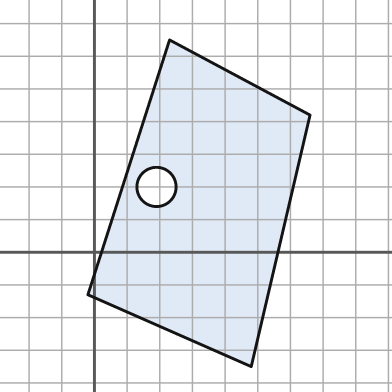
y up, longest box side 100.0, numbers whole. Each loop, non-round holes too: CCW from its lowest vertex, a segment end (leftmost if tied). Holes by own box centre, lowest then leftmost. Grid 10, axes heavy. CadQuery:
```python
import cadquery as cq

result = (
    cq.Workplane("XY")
    .moveTo(48.0, -35.0)
    .lineTo(66.0, 42.0)
    .lineTo(23.0, 65.0)
    .lineTo(-2.0, -13.0)
    .close()
    .moveTo(19.0, 20.0)
    .circle(6.0)
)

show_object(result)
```